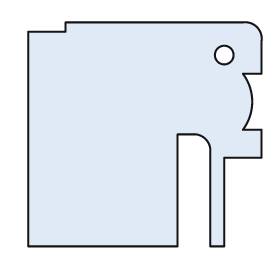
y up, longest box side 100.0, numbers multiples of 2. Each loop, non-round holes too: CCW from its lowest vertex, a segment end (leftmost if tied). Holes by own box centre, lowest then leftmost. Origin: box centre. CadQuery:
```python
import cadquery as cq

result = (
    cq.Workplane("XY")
    .moveTo(-50.0, -48.0)
    .lineTo(14.0, -48.0)
    .lineTo(14.0, 0.0)
    .lineTo(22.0, 0.0)
    .threePointArc((26.0, -2.0), (28.0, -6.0))
    .lineTo(28.0, -48.0)
    .lineTo(34.0, -48.0)
    .lineTo(34.0, -10.0)
    .lineTo(50.0, -10.0)
    .lineTo(50.0, 2.0)
    .lineTo(42.0, 2.0)
    .threePointArc((46.0, 14.0), (42.0, 26.0))
    .lineTo(50.0, 26.0)
    .lineTo(50.0, 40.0)
    .threePointArc((48.0, 46.0), (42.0, 48.0))
    .lineTo(-34.0, 48.0)
    .lineTo(-34.0, 44.0)
    .lineTo(-50.0, 44.0)
    .close()
    .moveTo(34.0, 34.0)
    .circle(4.0)
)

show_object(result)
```